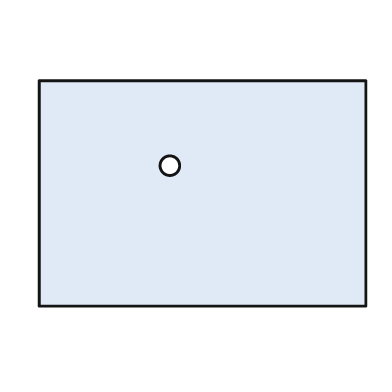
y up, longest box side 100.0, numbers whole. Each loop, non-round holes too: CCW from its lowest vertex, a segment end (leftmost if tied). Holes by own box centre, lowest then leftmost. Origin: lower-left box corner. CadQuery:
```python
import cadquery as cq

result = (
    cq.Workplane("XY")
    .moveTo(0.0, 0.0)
    .lineTo(100.0, 0.0)
    .lineTo(100.0, 69.0)
    .lineTo(0.0, 69.0)
    .close()
    .moveTo(40.0, 43.0)
    .circle(3.0)
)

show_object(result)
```